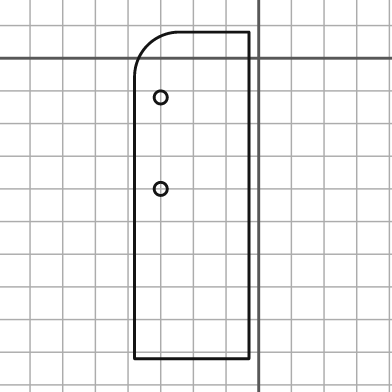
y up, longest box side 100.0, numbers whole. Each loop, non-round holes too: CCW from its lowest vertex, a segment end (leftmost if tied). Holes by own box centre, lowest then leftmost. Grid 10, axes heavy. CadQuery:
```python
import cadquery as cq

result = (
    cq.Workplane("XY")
    .moveTo(-38.0, -92.0)
    .lineTo(-3.0, -92.0)
    .lineTo(-3.0, 8.0)
    .lineTo(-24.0, 8.0)
    .threePointArc((-34.0, 4.0), (-38.0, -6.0))
    .close()
    .moveTo(-30.0, -40.0)
    .circle(2.0)
    .moveTo(-30.0, -12.0)
    .circle(2.0)
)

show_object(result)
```